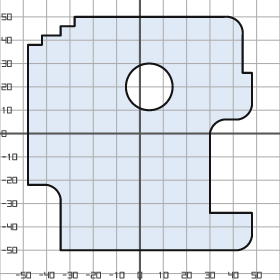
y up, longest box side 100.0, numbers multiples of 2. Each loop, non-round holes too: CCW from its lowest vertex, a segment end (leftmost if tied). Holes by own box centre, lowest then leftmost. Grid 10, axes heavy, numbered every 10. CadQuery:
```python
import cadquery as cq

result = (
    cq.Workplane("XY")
    .moveTo(-34.0, -50.0)
    .lineTo(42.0, -50.0)
    .threePointArc((46.0, -48.0), (48.0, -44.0))
    .lineTo(48.0, -34.0)
    .lineTo(30.0, -34.0)
    .lineTo(30.0, 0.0)
    .threePointArc((32.0, 4.0), (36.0, 6.0))
    .lineTo(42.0, 6.0)
    .threePointArc((46.0, 8.0), (48.0, 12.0))
    .lineTo(48.0, 26.0)
    .lineTo(44.0, 26.0)
    .lineTo(44.0, 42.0)
    .threePointArc((42.0, 48.0), (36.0, 50.0))
    .lineTo(-28.0, 50.0)
    .lineTo(-28.0, 46.0)
    .lineTo(-34.0, 46.0)
    .lineTo(-34.0, 42.0)
    .lineTo(-42.0, 42.0)
    .lineTo(-42.0, 38.0)
    .lineTo(-48.0, 38.0)
    .lineTo(-48.0, -22.0)
    .lineTo(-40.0, -22.0)
    .threePointArc((-36.0, -24.0), (-34.0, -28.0))
    .close()
    .moveTo(4.0, 20.0)
    .circle(10.0)
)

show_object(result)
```